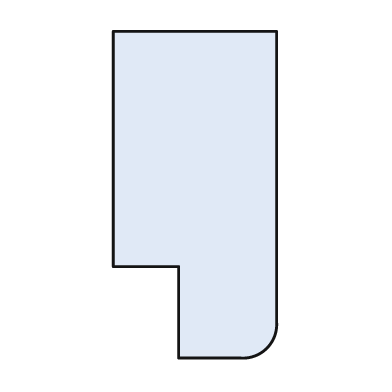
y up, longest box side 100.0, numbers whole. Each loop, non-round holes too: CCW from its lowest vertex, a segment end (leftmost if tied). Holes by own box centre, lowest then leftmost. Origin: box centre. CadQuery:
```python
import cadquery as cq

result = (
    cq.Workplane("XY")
    .moveTo(-5.0, -50.0)
    .lineTo(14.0, -50.0)
    .threePointArc((22.0, -47.0), (25.0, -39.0))
    .lineTo(25.0, 50.0)
    .lineTo(-25.0, 50.0)
    .lineTo(-25.0, -22.0)
    .lineTo(-5.0, -22.0)
    .close()
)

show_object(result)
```